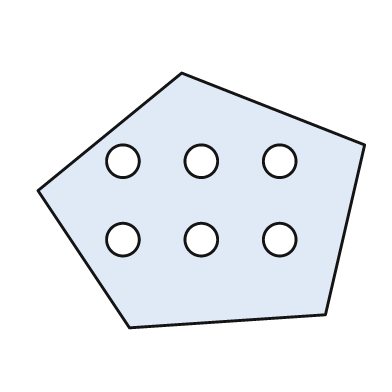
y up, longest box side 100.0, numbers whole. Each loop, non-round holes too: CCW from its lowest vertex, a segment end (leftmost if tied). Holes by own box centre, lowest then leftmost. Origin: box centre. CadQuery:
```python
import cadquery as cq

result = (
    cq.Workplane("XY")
    .moveTo(-22.0, -39.0)
    .lineTo(38.0, -35.0)
    .lineTo(50.0, 17.0)
    .lineTo(-6.0, 39.0)
    .lineTo(-50.0, 3.0)
    .close()
    .moveTo(-24.0, -12.0)
    .circle(5.0)
    .moveTo(0.0, -12.0)
    .circle(5.0)
    .moveTo(24.0, -12.0)
    .circle(5.0)
    .moveTo(-24.0, 12.0)
    .circle(5.0)
    .moveTo(0.0, 12.0)
    .circle(5.0)
    .moveTo(24.0, 12.0)
    .circle(5.0)
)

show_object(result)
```